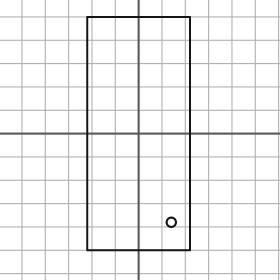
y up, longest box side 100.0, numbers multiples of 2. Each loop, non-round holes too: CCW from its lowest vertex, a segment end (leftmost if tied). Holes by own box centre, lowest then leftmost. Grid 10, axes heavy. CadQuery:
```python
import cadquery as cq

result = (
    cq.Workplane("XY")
    .moveTo(-22.0, -50.0)
    .lineTo(22.0, -50.0)
    .lineTo(22.0, 50.0)
    .lineTo(-22.0, 50.0)
    .close()
    .moveTo(14.0, -38.0)
    .circle(2.0)
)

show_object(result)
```